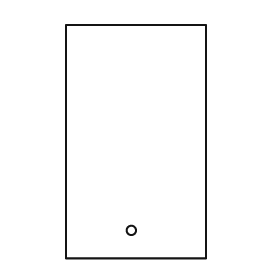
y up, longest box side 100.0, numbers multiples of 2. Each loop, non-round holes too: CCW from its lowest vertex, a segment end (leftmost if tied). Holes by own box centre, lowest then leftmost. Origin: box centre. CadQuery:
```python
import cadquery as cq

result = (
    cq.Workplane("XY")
    .moveTo(-30.0, -50.0)
    .lineTo(30.0, -50.0)
    .lineTo(30.0, 50.0)
    .lineTo(-30.0, 50.0)
    .close()
    .moveTo(-2.0, -38.0)
    .circle(2.0)
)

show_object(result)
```